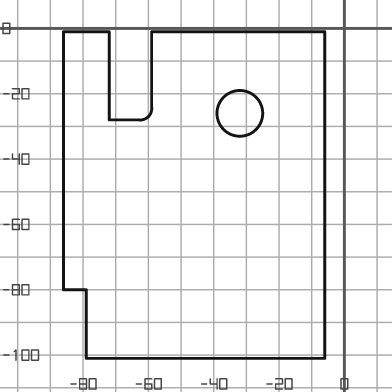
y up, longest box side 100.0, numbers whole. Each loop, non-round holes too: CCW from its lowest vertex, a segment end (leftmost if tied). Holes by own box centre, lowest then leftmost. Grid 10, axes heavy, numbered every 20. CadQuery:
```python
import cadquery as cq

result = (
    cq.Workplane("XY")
    .moveTo(-79.0, -101.0)
    .lineTo(-6.0, -101.0)
    .lineTo(-6.0, -1.0)
    .lineTo(-59.0, -1.0)
    .lineTo(-59.0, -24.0)
    .threePointArc((-60.0, -27.0), (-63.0, -28.0))
    .lineTo(-72.0, -28.0)
    .lineTo(-72.0, -1.0)
    .lineTo(-86.0, -1.0)
    .lineTo(-86.0, -80.0)
    .lineTo(-79.0, -80.0)
    .close()
    .moveTo(-32.0, -26.0)
    .circle(7.0)
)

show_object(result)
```